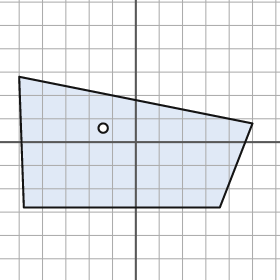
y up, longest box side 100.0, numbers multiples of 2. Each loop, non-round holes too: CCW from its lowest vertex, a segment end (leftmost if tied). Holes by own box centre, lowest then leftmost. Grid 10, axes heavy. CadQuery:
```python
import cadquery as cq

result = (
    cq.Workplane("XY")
    .moveTo(-48.0, -28.0)
    .lineTo(36.0, -28.0)
    .lineTo(50.0, 8.0)
    .lineTo(-50.0, 28.0)
    .close()
    .moveTo(-14.0, 6.0)
    .circle(2.0)
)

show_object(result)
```